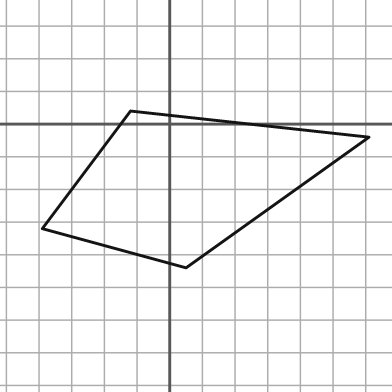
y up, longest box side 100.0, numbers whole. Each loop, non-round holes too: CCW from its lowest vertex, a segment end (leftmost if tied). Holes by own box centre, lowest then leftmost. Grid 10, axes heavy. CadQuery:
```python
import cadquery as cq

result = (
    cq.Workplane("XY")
    .moveTo(5.0, -44.0)
    .lineTo(61.0, -4.0)
    .lineTo(-12.0, 4.0)
    .lineTo(-39.0, -32.0)
    .close()
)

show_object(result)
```